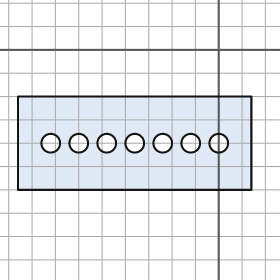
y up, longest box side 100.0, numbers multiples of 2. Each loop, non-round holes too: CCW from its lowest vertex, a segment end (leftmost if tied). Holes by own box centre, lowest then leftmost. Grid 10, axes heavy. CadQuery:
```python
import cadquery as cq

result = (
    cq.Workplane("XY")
    .moveTo(-86.0, -60.0)
    .lineTo(14.0, -60.0)
    .lineTo(14.0, -20.0)
    .lineTo(-86.0, -20.0)
    .close()
    .moveTo(-72.0, -40.0)
    .circle(4.0)
    .moveTo(-60.0, -40.0)
    .circle(4.0)
    .moveTo(-48.0, -40.0)
    .circle(4.0)
    .moveTo(-36.0, -40.0)
    .circle(4.0)
    .moveTo(-24.0, -40.0)
    .circle(4.0)
    .moveTo(-12.0, -40.0)
    .circle(4.0)
    .moveTo(0.0, -40.0)
    .circle(4.0)
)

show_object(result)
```